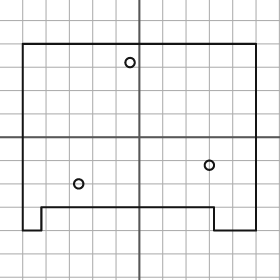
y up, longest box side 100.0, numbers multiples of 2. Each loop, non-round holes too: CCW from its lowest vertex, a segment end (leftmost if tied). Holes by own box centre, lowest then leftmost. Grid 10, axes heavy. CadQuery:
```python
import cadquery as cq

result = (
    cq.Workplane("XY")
    .moveTo(-50.0, -40.0)
    .lineTo(-42.0, -40.0)
    .lineTo(-42.0, -30.0)
    .lineTo(32.0, -30.0)
    .lineTo(32.0, -40.0)
    .lineTo(50.0, -40.0)
    .lineTo(50.0, 40.0)
    .lineTo(-50.0, 40.0)
    .close()
    .moveTo(-26.0, -20.0)
    .circle(2.0)
    .moveTo(30.0, -12.0)
    .circle(2.0)
    .moveTo(-4.0, 32.0)
    .circle(2.0)
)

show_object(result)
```